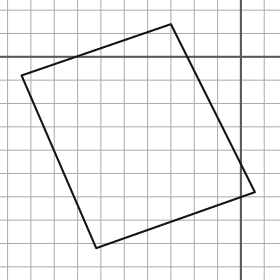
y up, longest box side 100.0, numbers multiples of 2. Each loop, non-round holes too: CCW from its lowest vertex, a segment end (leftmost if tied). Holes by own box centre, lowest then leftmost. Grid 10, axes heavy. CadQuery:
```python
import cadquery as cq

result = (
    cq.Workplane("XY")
    .moveTo(-62.0, -82.0)
    .lineTo(6.0, -58.0)
    .lineTo(-30.0, 14.0)
    .lineTo(-94.0, -8.0)
    .close()
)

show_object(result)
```